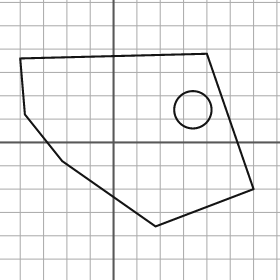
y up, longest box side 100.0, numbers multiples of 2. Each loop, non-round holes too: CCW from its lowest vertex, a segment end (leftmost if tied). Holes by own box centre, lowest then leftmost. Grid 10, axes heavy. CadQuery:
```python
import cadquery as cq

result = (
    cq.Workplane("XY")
    .moveTo(18.0, -36.0)
    .lineTo(60.0, -20.0)
    .lineTo(40.0, 38.0)
    .lineTo(-40.0, 36.0)
    .lineTo(-38.0, 12.0)
    .lineTo(-22.0, -8.0)
    .close()
    .moveTo(34.0, 14.0)
    .circle(8.0)
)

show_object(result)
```